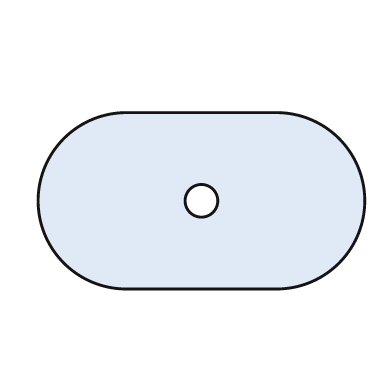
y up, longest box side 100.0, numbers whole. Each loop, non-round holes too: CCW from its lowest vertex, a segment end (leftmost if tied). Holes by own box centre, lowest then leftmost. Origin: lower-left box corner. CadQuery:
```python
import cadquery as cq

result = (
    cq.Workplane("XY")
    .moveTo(27.0, 0.0)
    .lineTo(73.0, 0.0)
    .threePointArc((100.0, 27.0), (73.0, 54.0))
    .lineTo(27.0, 54.0)
    .threePointArc((0.0, 27.0), (27.0, 0.0))
    .close()
    .moveTo(50.0, 27.0)
    .circle(5.0)
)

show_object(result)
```